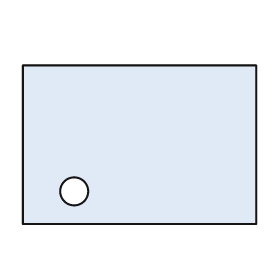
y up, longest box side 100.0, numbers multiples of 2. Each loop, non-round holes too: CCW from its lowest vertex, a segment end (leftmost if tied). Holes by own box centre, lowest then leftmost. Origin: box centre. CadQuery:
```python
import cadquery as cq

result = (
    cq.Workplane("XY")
    .moveTo(-50.0, -34.0)
    .lineTo(50.0, -34.0)
    .lineTo(50.0, 34.0)
    .lineTo(-50.0, 34.0)
    .close()
    .moveTo(-28.0, -20.0)
    .circle(6.0)
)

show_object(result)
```